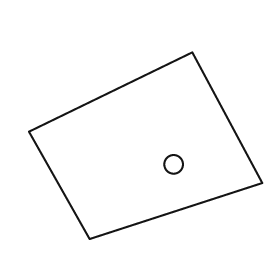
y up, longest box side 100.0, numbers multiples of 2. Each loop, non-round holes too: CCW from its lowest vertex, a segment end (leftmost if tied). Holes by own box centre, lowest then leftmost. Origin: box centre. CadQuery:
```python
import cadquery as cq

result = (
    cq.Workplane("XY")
    .moveTo(-24.0, -40.0)
    .lineTo(50.0, -16.0)
    .lineTo(20.0, 40.0)
    .lineTo(-50.0, 6.0)
    .close()
    .moveTo(12.0, -8.0)
    .circle(4.0)
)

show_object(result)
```